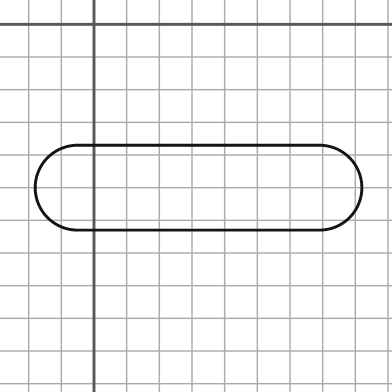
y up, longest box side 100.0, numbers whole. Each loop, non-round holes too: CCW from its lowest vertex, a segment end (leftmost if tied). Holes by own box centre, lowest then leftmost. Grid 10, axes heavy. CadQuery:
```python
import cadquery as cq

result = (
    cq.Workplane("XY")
    .moveTo(-5.0, -63.0)
    .lineTo(69.0, -63.0)
    .threePointArc((82.0, -50.0), (69.0, -37.0))
    .lineTo(-5.0, -37.0)
    .threePointArc((-18.0, -50.0), (-5.0, -63.0))
    .close()
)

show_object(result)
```